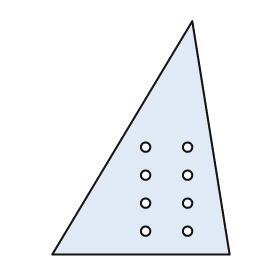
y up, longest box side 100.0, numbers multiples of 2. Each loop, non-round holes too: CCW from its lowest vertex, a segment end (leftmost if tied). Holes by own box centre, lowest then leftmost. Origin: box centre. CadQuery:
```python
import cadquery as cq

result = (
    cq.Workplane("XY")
    .moveTo(-38.0, -50.0)
    .lineTo(38.0, -50.0)
    .lineTo(22.0, 50.0)
    .close()
    .moveTo(2.0, -40.0)
    .circle(2.0)
    .moveTo(20.0, -40.0)
    .circle(2.0)
    .moveTo(2.0, -28.0)
    .circle(2.0)
    .moveTo(20.0, -28.0)
    .circle(2.0)
    .moveTo(2.0, -16.0)
    .circle(2.0)
    .moveTo(20.0, -16.0)
    .circle(2.0)
    .moveTo(2.0, -4.0)
    .circle(2.0)
    .moveTo(20.0, -4.0)
    .circle(2.0)
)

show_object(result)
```